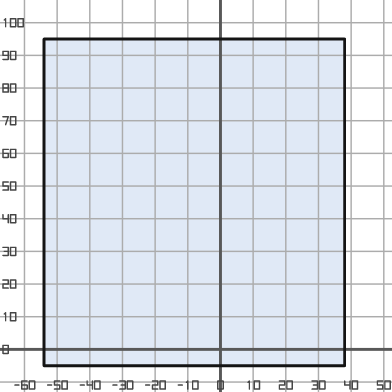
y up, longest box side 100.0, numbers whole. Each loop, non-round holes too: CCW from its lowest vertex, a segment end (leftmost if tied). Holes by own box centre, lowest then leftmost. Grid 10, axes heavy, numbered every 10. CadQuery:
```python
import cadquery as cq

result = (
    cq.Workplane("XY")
    .moveTo(-54.0, -5.0)
    .lineTo(38.0, -5.0)
    .lineTo(38.0, 95.0)
    .lineTo(-54.0, 95.0)
    .close()
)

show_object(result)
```